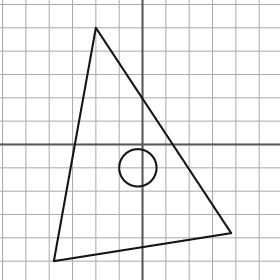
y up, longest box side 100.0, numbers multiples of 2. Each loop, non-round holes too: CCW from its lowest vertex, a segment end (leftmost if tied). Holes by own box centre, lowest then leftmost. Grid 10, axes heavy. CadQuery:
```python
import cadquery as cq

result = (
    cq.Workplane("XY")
    .moveTo(-38.0, -50.0)
    .lineTo(38.0, -38.0)
    .lineTo(-20.0, 50.0)
    .close()
    .moveTo(-2.0, -10.0)
    .circle(8.0)
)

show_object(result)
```